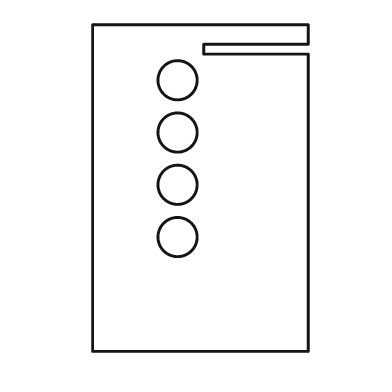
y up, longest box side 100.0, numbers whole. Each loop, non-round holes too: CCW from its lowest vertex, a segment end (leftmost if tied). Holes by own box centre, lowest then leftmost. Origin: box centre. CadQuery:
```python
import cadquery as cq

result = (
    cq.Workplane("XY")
    .moveTo(-33.0, -50.0)
    .lineTo(33.0, -50.0)
    .lineTo(33.0, 41.0)
    .lineTo(1.0, 41.0)
    .lineTo(1.0, 44.0)
    .lineTo(33.0, 44.0)
    .lineTo(33.0, 50.0)
    .lineTo(-33.0, 50.0)
    .close()
    .moveTo(-7.0, -15.0)
    .circle(6.0)
    .moveTo(-7.0, 1.0)
    .circle(6.0)
    .moveTo(-7.0, 17.0)
    .circle(6.0)
    .moveTo(-7.0, 33.0)
    .circle(6.0)
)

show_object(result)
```